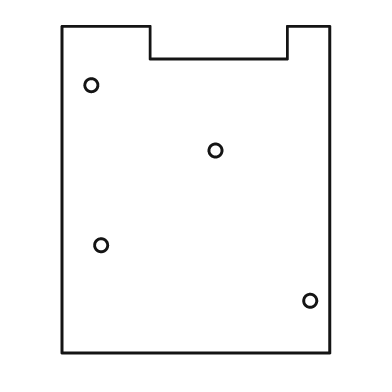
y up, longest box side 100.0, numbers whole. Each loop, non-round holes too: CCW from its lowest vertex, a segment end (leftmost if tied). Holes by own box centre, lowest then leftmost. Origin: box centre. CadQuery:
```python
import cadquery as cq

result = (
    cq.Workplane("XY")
    .moveTo(-41.0, -50.0)
    .lineTo(41.0, -50.0)
    .lineTo(41.0, 50.0)
    .lineTo(28.0, 50.0)
    .lineTo(28.0, 40.0)
    .lineTo(-14.0, 40.0)
    .lineTo(-14.0, 50.0)
    .lineTo(-41.0, 50.0)
    .close()
    .moveTo(35.0, -34.0)
    .circle(2.0)
    .moveTo(-29.0, -17.0)
    .circle(2.0)
    .moveTo(6.0, 12.0)
    .circle(2.0)
    .moveTo(-32.0, 32.0)
    .circle(2.0)
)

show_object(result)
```